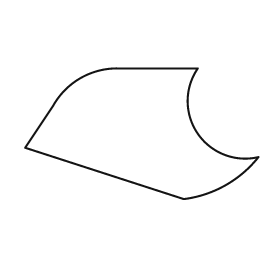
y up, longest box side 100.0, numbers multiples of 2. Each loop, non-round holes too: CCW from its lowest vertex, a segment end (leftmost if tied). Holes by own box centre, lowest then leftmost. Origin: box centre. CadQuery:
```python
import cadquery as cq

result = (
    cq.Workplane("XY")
    .moveTo(18.0, -28.0)
    .threePointArc((36.0, -22.0), (50.0, -10.0))
    .threePointArc((24.0, 0.0), (24.0, 28.0))
    .lineTo(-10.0, 28.0)
    .threePointArc((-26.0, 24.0), (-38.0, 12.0))
    .lineTo(-50.0, -6.0)
    .close()
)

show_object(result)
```